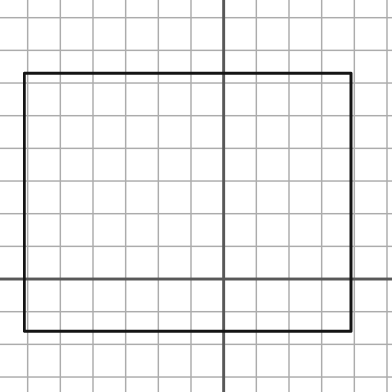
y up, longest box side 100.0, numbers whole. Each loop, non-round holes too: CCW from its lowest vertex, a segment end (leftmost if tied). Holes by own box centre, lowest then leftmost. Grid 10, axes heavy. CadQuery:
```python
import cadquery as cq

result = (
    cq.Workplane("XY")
    .moveTo(-61.0, -16.0)
    .lineTo(39.0, -16.0)
    .lineTo(39.0, 63.0)
    .lineTo(-61.0, 63.0)
    .close()
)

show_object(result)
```